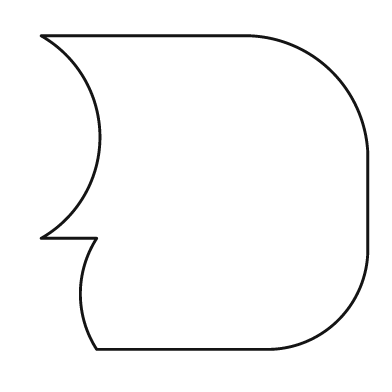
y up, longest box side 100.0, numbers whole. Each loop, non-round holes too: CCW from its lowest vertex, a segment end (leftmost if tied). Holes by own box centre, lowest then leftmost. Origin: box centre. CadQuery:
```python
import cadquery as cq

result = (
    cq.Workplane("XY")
    .moveTo(-33.0, -48.0)
    .lineTo(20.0, -48.0)
    .threePointArc((41.0, -39.0), (50.0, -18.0))
    .lineTo(50.0, 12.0)
    .threePointArc((39.0, 37.0), (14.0, 48.0))
    .lineTo(-50.0, 48.0)
    .threePointArc((-32.0, 17.0), (-50.0, -14.0))
    .lineTo(-33.0, -14.0)
    .threePointArc((-38.0, -31.0), (-33.0, -48.0))
    .close()
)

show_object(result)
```